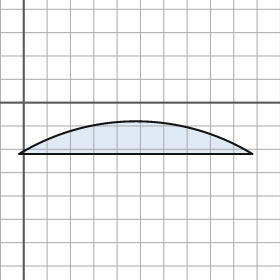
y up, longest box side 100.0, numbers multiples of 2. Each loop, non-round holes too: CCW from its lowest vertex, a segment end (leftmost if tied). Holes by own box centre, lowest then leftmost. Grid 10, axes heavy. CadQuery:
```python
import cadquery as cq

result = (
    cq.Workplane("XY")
    .moveTo(-2.0, -22.0)
    .lineTo(98.0, -22.0)
    .threePointArc((48.0, -8.0), (-2.0, -22.0))
    .close()
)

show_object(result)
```